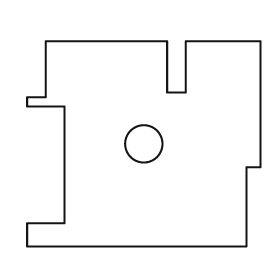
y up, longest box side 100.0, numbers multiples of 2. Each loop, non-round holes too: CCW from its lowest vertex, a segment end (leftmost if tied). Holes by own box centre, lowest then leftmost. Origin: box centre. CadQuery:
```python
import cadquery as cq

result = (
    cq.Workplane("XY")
    .moveTo(-50.0, -44.0)
    .lineTo(44.0, -44.0)
    .lineTo(44.0, -10.0)
    .lineTo(50.0, -10.0)
    .lineTo(50.0, 44.0)
    .lineTo(18.0, 44.0)
    .lineTo(18.0, 22.0)
    .lineTo(10.0, 22.0)
    .lineTo(10.0, 44.0)
    .lineTo(-42.0, 44.0)
    .lineTo(-42.0, 20.0)
    .lineTo(-50.0, 20.0)
    .lineTo(-50.0, 16.0)
    .lineTo(-34.0, 16.0)
    .lineTo(-34.0, -34.0)
    .lineTo(-50.0, -34.0)
    .close()
    .moveTo(0.0, 0.0)
    .circle(8.0)
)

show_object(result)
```